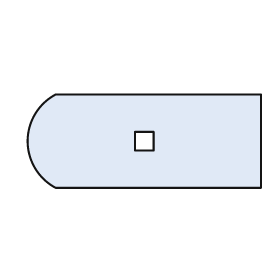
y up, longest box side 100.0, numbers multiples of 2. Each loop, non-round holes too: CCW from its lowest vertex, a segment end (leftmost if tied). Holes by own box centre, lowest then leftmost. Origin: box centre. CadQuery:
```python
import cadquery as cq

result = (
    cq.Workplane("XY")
    .moveTo(-38.0, -20.0)
    .lineTo(50.0, -20.0)
    .lineTo(50.0, 20.0)
    .lineTo(-38.0, 20.0)
    .threePointArc((-50.0, 0.0), (-38.0, -20.0))
    .close()
    .moveTo(-4.0, -4.0)
    .lineTo(4.0, -4.0)
    .lineTo(4.0, 4.0)
    .lineTo(-4.0, 4.0)
    .close()
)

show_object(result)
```